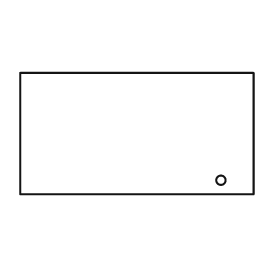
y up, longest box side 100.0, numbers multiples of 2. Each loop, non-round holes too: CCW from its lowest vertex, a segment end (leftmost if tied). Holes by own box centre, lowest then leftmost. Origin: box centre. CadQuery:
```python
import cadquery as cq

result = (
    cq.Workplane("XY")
    .moveTo(-50.0, -26.0)
    .lineTo(50.0, -26.0)
    .lineTo(50.0, 26.0)
    .lineTo(-50.0, 26.0)
    .close()
    .moveTo(36.0, -20.0)
    .circle(2.0)
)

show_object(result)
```